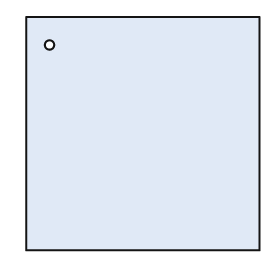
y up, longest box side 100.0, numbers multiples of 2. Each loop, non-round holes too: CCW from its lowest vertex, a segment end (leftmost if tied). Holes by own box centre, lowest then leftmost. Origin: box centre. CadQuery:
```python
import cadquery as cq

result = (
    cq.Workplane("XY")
    .moveTo(-50.0, -50.0)
    .lineTo(50.0, -50.0)
    .lineTo(50.0, 50.0)
    .lineTo(-50.0, 50.0)
    .close()
    .moveTo(-40.0, 38.0)
    .circle(2.0)
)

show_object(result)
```